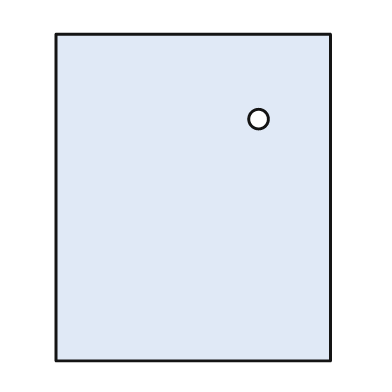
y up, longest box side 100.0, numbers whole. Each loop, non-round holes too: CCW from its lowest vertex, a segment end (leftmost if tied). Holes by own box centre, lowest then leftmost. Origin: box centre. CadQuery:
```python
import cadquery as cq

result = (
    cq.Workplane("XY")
    .moveTo(-42.0, -50.0)
    .lineTo(42.0, -50.0)
    .lineTo(42.0, 50.0)
    .lineTo(-42.0, 50.0)
    .close()
    .moveTo(20.0, 24.0)
    .circle(3.0)
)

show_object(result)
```